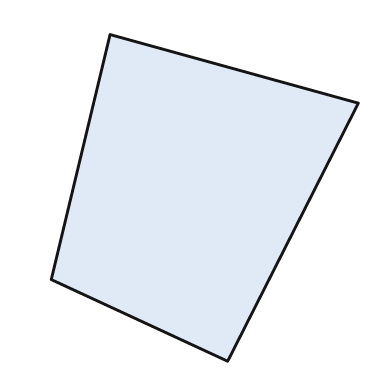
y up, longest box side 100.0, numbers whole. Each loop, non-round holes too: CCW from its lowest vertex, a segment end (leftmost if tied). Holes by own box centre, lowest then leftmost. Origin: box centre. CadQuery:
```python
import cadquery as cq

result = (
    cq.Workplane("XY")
    .moveTo(7.0, -50.0)
    .lineTo(47.0, 29.0)
    .lineTo(-29.0, 50.0)
    .lineTo(-47.0, -25.0)
    .close()
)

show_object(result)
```